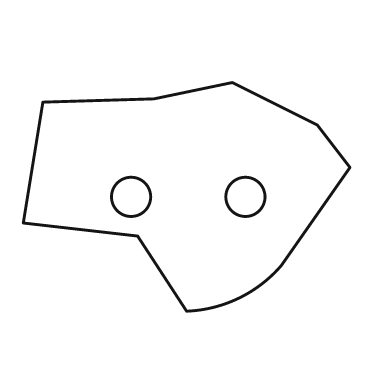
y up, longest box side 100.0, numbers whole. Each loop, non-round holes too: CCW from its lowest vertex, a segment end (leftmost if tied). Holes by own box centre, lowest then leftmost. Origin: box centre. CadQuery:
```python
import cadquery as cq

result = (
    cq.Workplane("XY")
    .moveTo(0.0, -35.0)
    .threePointArc((16.0, -31.0), (29.0, -21.0))
    .lineTo(50.0, 9.0)
    .lineTo(40.0, 22.0)
    .lineTo(14.0, 35.0)
    .lineTo(-10.0, 30.0)
    .lineTo(-44.0, 29.0)
    .lineTo(-50.0, -8.0)
    .lineTo(-15.0, -12.0)
    .close()
    .moveTo(-17.0, 0.0)
    .circle(6.0)
    .moveTo(18.0, 0.0)
    .circle(6.0)
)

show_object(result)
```